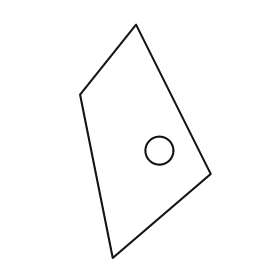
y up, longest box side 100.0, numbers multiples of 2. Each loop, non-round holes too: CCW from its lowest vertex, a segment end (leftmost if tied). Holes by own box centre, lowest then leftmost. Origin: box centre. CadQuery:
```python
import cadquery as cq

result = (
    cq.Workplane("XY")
    .moveTo(-14.0, -50.0)
    .lineTo(28.0, -14.0)
    .lineTo(-4.0, 50.0)
    .lineTo(-28.0, 20.0)
    .close()
    .moveTo(6.0, -4.0)
    .circle(6.0)
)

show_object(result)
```